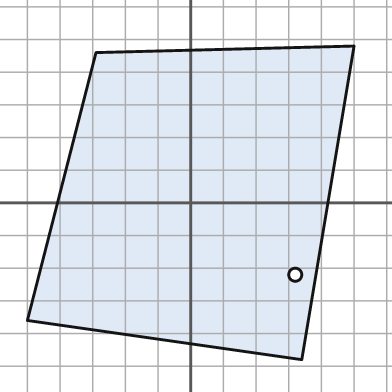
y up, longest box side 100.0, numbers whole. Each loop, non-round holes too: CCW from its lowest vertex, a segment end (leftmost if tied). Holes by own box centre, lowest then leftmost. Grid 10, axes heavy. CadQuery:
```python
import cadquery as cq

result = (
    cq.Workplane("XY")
    .moveTo(34.0, -48.0)
    .lineTo(50.0, 48.0)
    .lineTo(-29.0, 46.0)
    .lineTo(-50.0, -36.0)
    .close()
    .moveTo(32.0, -22.0)
    .circle(2.0)
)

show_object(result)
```